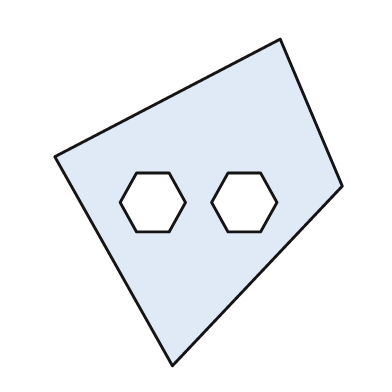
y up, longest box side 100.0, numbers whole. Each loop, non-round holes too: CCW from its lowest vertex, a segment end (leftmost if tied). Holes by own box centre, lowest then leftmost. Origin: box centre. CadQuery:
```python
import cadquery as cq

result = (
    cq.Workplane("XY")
    .moveTo(-8.0, -50.0)
    .lineTo(44.0, 5.0)
    .lineTo(25.0, 50.0)
    .lineTo(-44.0, 14.0)
    .close()
    .moveTo(-19.0, -9.0)
    .lineTo(-9.0, -9.0)
    .lineTo(-4.0, 0.0)
    .lineTo(-9.0, 9.0)
    .lineTo(-19.0, 9.0)
    .lineTo(-24.0, 0.0)
    .close()
    .moveTo(9.0, -9.0)
    .lineTo(19.0, -9.0)
    .lineTo(24.0, 0.0)
    .lineTo(19.0, 9.0)
    .lineTo(9.0, 9.0)
    .lineTo(4.0, 0.0)
    .close()
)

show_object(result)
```